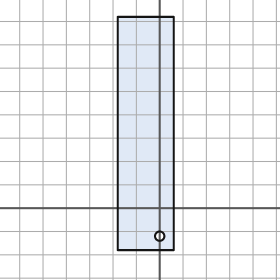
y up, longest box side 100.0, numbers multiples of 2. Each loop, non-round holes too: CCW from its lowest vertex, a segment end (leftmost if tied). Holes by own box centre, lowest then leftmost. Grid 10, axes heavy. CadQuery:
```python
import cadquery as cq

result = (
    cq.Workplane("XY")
    .moveTo(-18.0, -18.0)
    .lineTo(6.0, -18.0)
    .lineTo(6.0, 82.0)
    .lineTo(-18.0, 82.0)
    .close()
    .moveTo(0.0, -12.0)
    .circle(2.0)
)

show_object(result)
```